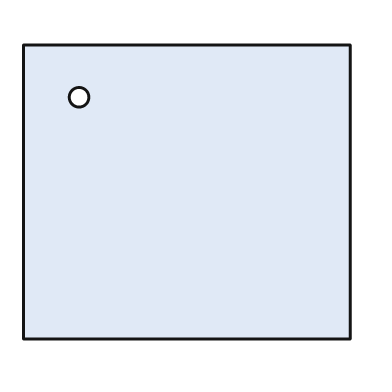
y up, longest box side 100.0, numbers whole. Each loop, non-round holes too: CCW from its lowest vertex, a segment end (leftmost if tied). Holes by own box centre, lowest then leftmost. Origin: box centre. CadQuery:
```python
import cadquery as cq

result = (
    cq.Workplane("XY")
    .moveTo(-50.0, -45.0)
    .lineTo(50.0, -45.0)
    .lineTo(50.0, 45.0)
    .lineTo(-50.0, 45.0)
    .close()
    .moveTo(-33.0, 29.0)
    .circle(3.0)
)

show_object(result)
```